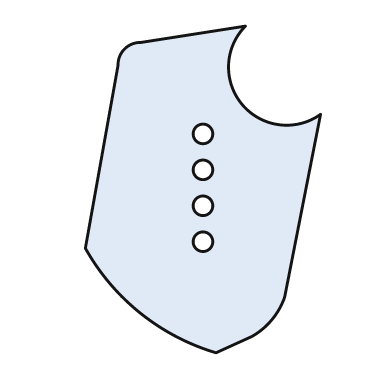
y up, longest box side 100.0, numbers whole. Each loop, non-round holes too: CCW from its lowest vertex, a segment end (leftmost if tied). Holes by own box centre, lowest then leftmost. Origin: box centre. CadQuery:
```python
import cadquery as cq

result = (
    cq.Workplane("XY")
    .moveTo(4.0, -50.0)
    .lineTo(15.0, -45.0)
    .threePointArc((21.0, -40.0), (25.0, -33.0))
    .lineTo(36.0, 23.0)
    .threePointArc((12.0, 26.0), (13.0, 50.0))
    .lineTo(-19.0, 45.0)
    .threePointArc((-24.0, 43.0), (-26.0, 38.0))
    .lineTo(-36.0, -18.0)
    .threePointArc((-19.0, -38.0), (4.0, -50.0))
    .close()
    .moveTo(0.0, -16.0)
    .circle(3.0)
    .moveTo(0.0, -5.0)
    .circle(3.0)
    .moveTo(0.0, 6.0)
    .circle(3.0)
    .moveTo(0.0, 17.0)
    .circle(3.0)
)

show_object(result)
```